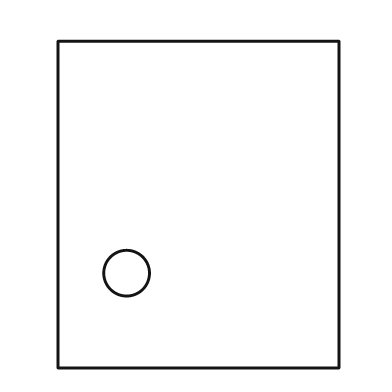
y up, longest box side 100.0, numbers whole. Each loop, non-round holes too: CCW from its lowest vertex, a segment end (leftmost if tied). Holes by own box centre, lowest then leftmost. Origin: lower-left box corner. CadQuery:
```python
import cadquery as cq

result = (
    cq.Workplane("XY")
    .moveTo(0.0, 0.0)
    .lineTo(86.0, 0.0)
    .lineTo(86.0, 100.0)
    .lineTo(0.0, 100.0)
    .close()
    .moveTo(21.0, 29.0)
    .circle(7.0)
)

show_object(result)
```